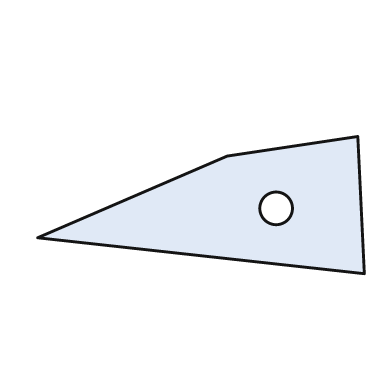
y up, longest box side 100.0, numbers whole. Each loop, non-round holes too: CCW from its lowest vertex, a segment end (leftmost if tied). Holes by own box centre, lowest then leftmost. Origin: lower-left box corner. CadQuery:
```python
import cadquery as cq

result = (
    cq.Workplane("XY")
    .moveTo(100.0, 0.0)
    .lineTo(98.0, 42.0)
    .lineTo(58.0, 36.0)
    .lineTo(0.0, 11.0)
    .close()
    .moveTo(73.0, 20.0)
    .circle(5.0)
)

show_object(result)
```